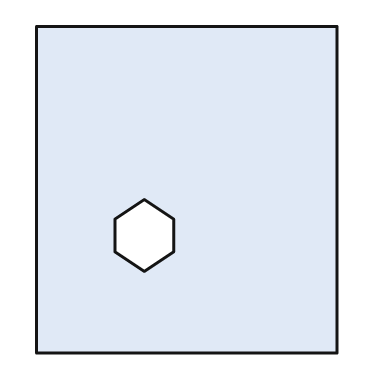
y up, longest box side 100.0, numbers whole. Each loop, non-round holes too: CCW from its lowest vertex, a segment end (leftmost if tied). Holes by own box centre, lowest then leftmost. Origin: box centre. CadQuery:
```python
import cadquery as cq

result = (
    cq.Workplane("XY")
    .moveTo(-46.0, -50.0)
    .lineTo(46.0, -50.0)
    .lineTo(46.0, 50.0)
    .lineTo(-46.0, 50.0)
    .close()
    .moveTo(-13.0, -25.0)
    .lineTo(-4.0, -19.0)
    .lineTo(-4.0, -9.0)
    .lineTo(-13.0, -3.0)
    .lineTo(-22.0, -9.0)
    .lineTo(-22.0, -19.0)
    .close()
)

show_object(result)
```